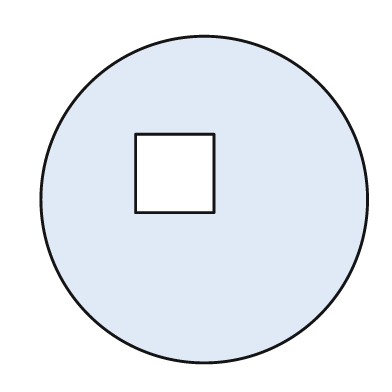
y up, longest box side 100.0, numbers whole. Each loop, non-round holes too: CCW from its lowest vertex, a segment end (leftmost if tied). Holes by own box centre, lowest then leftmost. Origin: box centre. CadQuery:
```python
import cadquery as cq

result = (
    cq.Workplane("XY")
    .moveTo(0.0, 0.0)
    .circle(50.0)
    .moveTo(-21.0, -4.0)
    .lineTo(3.0, -4.0)
    .lineTo(3.0, 20.0)
    .lineTo(-21.0, 20.0)
    .close()
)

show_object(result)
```